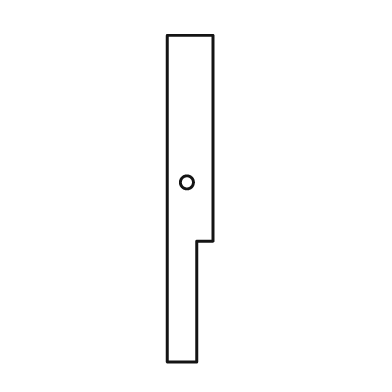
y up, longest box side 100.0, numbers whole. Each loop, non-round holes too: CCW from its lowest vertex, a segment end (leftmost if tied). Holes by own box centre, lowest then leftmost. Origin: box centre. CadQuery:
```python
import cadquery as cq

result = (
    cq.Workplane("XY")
    .moveTo(-7.0, -50.0)
    .lineTo(2.0, -50.0)
    .lineTo(2.0, -13.0)
    .lineTo(7.0, -13.0)
    .lineTo(7.0, 50.0)
    .lineTo(-7.0, 50.0)
    .close()
    .moveTo(-1.0, 5.0)
    .circle(2.0)
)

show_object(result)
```